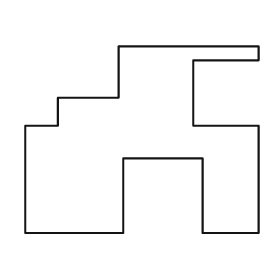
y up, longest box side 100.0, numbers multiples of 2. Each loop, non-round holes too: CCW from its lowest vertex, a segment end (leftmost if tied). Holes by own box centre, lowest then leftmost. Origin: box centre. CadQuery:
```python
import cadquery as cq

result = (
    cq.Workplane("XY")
    .moveTo(-50.0, -40.0)
    .lineTo(-8.0, -40.0)
    .lineTo(-8.0, -8.0)
    .lineTo(26.0, -8.0)
    .lineTo(26.0, -40.0)
    .lineTo(50.0, -40.0)
    .lineTo(50.0, 6.0)
    .lineTo(22.0, 6.0)
    .lineTo(22.0, 34.0)
    .lineTo(50.0, 34.0)
    .lineTo(50.0, 40.0)
    .lineTo(-10.0, 40.0)
    .lineTo(-10.0, 18.0)
    .lineTo(-36.0, 18.0)
    .lineTo(-36.0, 6.0)
    .lineTo(-50.0, 6.0)
    .close()
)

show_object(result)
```